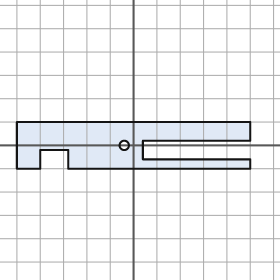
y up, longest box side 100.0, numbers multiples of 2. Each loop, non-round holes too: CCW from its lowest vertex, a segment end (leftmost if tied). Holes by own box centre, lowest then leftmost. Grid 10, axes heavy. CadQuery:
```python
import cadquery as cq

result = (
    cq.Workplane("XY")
    .moveTo(-50.0, -10.0)
    .lineTo(-40.0, -10.0)
    .lineTo(-40.0, -2.0)
    .lineTo(-28.0, -2.0)
    .lineTo(-28.0, -10.0)
    .lineTo(50.0, -10.0)
    .lineTo(50.0, -6.0)
    .lineTo(4.0, -6.0)
    .lineTo(4.0, 2.0)
    .lineTo(50.0, 2.0)
    .lineTo(50.0, 10.0)
    .lineTo(-50.0, 10.0)
    .close()
    .moveTo(-4.0, 0.0)
    .circle(2.0)
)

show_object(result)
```